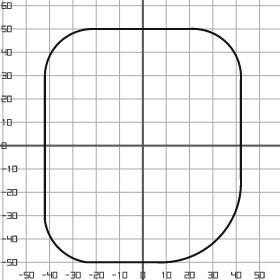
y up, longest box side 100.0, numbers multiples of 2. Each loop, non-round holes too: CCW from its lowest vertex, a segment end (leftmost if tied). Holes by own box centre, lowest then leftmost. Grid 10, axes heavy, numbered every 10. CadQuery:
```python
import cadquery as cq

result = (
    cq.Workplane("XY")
    .moveTo(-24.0, -50.0)
    .lineTo(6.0, -50.0)
    .threePointArc((32.0, -40.0), (42.0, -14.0))
    .lineTo(42.0, 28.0)
    .threePointArc((36.0, 44.0), (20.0, 50.0))
    .lineTo(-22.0, 50.0)
    .threePointArc((-36.0, 44.0), (-42.0, 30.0))
    .lineTo(-42.0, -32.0)
    .threePointArc((-36.0, -44.0), (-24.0, -50.0))
    .close()
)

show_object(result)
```